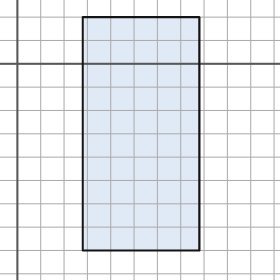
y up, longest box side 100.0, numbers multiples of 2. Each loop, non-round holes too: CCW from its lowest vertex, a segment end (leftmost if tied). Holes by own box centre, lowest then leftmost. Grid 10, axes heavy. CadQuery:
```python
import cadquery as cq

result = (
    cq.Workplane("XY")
    .moveTo(28.0, -80.0)
    .lineTo(78.0, -80.0)
    .lineTo(78.0, 20.0)
    .lineTo(28.0, 20.0)
    .close()
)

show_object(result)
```